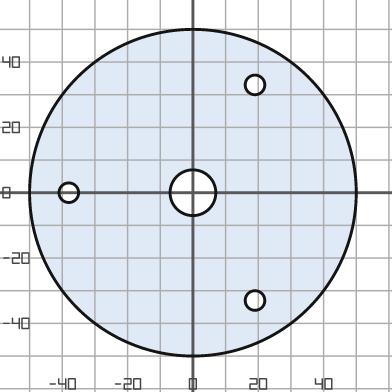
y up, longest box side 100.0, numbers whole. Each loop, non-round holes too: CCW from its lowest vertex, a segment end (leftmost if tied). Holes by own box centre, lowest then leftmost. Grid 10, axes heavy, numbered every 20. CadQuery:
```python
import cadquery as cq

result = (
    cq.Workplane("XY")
    .moveTo(0.0, 0.0)
    .circle(50.0)
    .moveTo(19.0, -33.0)
    .circle(3.0)
    .moveTo(-38.0, 0.0)
    .circle(3.0)
    .moveTo(0.0, 0.0)
    .circle(7.0)
    .moveTo(19.0, 33.0)
    .circle(3.0)
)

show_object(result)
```